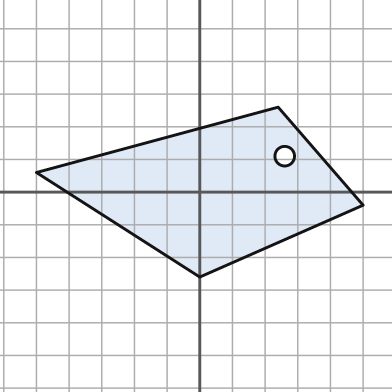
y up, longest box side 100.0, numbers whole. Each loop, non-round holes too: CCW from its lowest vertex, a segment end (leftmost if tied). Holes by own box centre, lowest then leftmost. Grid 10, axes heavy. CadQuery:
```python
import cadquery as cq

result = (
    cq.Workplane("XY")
    .moveTo(0.0, -26.0)
    .lineTo(50.0, -4.0)
    .lineTo(24.0, 26.0)
    .lineTo(-50.0, 6.0)
    .close()
    .moveTo(26.0, 11.0)
    .circle(3.0)
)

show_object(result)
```